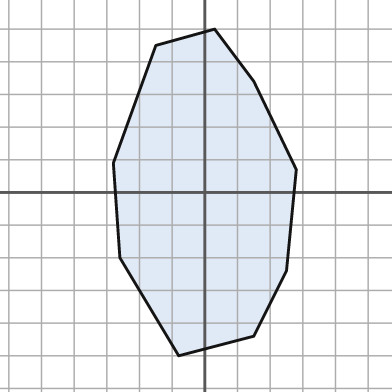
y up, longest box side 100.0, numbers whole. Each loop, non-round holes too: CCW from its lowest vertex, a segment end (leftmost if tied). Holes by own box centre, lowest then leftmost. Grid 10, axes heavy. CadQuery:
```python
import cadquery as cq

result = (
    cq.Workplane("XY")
    .moveTo(-8.0, -50.0)
    .lineTo(15.0, -44.0)
    .lineTo(25.0, -24.0)
    .lineTo(28.0, 7.0)
    .lineTo(15.0, 34.0)
    .lineTo(3.0, 50.0)
    .lineTo(-15.0, 45.0)
    .lineTo(-28.0, 9.0)
    .lineTo(-26.0, -20.0)
    .close()
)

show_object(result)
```